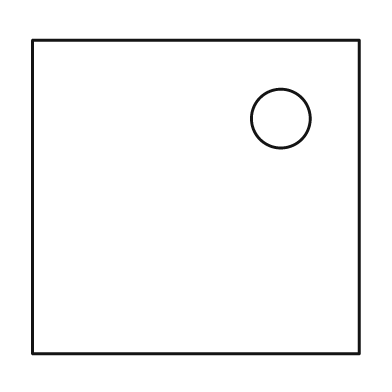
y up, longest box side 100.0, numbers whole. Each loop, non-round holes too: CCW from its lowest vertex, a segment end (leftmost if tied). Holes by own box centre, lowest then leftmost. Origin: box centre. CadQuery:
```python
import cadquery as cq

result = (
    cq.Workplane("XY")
    .moveTo(-50.0, -48.0)
    .lineTo(50.0, -48.0)
    .lineTo(50.0, 48.0)
    .lineTo(-50.0, 48.0)
    .close()
    .moveTo(26.0, 24.0)
    .circle(9.0)
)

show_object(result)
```